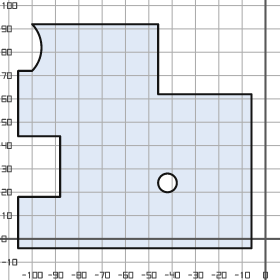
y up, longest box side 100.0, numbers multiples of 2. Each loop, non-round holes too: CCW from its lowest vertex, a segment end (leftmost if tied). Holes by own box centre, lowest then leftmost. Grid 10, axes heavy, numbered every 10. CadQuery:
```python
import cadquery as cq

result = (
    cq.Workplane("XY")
    .moveTo(-106.0, -4.0)
    .lineTo(-6.0, -4.0)
    .lineTo(-6.0, 62.0)
    .lineTo(-46.0, 62.0)
    .lineTo(-46.0, 92.0)
    .lineTo(-100.0, 92.0)
    .threePointArc((-96.0, 82.0), (-100.0, 72.0))
    .lineTo(-106.0, 72.0)
    .lineTo(-106.0, 44.0)
    .lineTo(-88.0, 44.0)
    .lineTo(-88.0, 18.0)
    .lineTo(-106.0, 18.0)
    .close()
    .moveTo(-42.0, 24.0)
    .circle(4.0)
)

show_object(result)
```